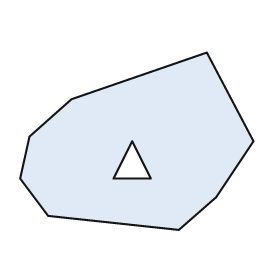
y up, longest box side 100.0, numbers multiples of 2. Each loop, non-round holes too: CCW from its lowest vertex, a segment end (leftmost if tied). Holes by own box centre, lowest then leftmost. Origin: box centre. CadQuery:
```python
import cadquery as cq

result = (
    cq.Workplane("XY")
    .moveTo(18.0, -38.0)
    .lineTo(34.0, -24.0)
    .lineTo(50.0, 0.0)
    .lineTo(30.0, 38.0)
    .lineTo(-28.0, 18.0)
    .lineTo(-46.0, 2.0)
    .lineTo(-50.0, -16.0)
    .lineTo(-38.0, -32.0)
    .close()
    .moveTo(-10.0, -16.0)
    .lineTo(6.0, -16.0)
    .lineTo(-2.0, 0.0)
    .close()
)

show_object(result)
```